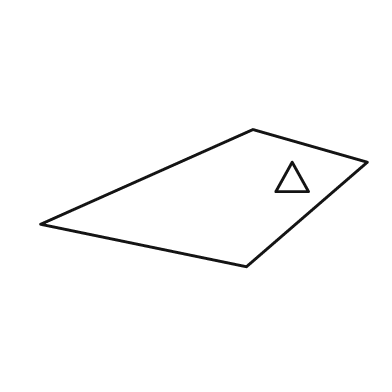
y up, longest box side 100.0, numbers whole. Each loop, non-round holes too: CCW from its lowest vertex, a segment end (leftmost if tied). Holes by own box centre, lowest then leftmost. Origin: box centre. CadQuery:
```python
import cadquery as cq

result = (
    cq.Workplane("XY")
    .moveTo(13.0, -21.0)
    .lineTo(50.0, 11.0)
    .lineTo(15.0, 21.0)
    .lineTo(-50.0, -8.0)
    .close()
    .moveTo(22.0, 2.0)
    .lineTo(32.0, 2.0)
    .lineTo(27.0, 11.0)
    .close()
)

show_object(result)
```